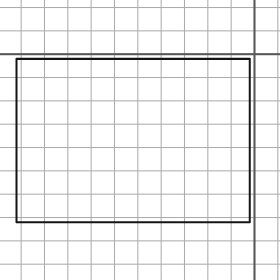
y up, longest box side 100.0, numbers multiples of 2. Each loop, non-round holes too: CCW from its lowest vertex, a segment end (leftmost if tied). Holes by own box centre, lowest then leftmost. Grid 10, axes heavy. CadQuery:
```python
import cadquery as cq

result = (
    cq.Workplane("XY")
    .moveTo(-102.0, -72.0)
    .lineTo(-2.0, -72.0)
    .lineTo(-2.0, -2.0)
    .lineTo(-102.0, -2.0)
    .close()
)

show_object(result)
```